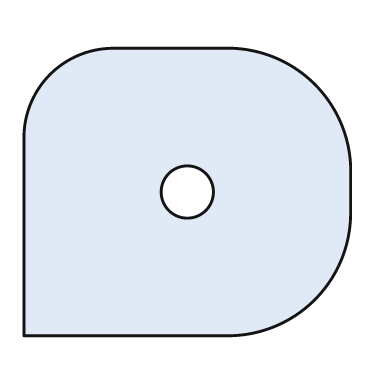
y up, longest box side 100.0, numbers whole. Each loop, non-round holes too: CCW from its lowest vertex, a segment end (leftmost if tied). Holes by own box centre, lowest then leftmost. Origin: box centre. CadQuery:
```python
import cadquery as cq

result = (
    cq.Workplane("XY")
    .moveTo(-50.0, -44.0)
    .lineTo(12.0, -44.0)
    .threePointArc((39.0, -33.0), (50.0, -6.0))
    .lineTo(50.0, 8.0)
    .threePointArc((39.0, 33.0), (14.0, 44.0))
    .lineTo(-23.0, 44.0)
    .threePointArc((-42.0, 36.0), (-50.0, 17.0))
    .close()
    .moveTo(0.0, 0.0)
    .circle(8.0)
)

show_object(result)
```